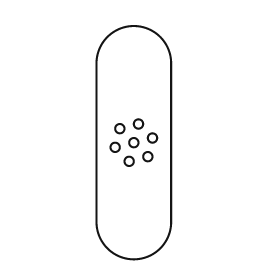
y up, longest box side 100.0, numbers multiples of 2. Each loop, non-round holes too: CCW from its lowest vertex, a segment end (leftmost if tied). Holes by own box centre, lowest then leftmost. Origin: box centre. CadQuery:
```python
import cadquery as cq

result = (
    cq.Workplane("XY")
    .moveTo(-16.0, -34.0)
    .threePointArc((0.0, -50.0), (16.0, -34.0))
    .lineTo(16.0, 34.0)
    .threePointArc((0.0, 50.0), (-16.0, 34.0))
    .close()
    .moveTo(-2.0, -8.0)
    .circle(2.0)
    .moveTo(6.0, -6.0)
    .circle(2.0)
    .moveTo(-8.0, -2.0)
    .circle(2.0)
    .moveTo(0.0, 0.0)
    .circle(2.0)
    .moveTo(8.0, 2.0)
    .circle(2.0)
    .moveTo(-6.0, 6.0)
    .circle(2.0)
    .moveTo(2.0, 8.0)
    .circle(2.0)
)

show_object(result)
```